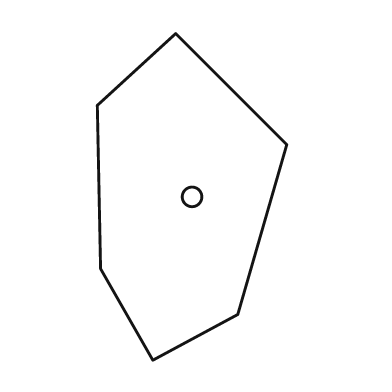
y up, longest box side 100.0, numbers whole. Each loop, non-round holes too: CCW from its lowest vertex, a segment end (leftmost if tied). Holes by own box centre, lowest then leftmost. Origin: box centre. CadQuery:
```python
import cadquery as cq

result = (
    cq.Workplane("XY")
    .moveTo(-12.0, -50.0)
    .lineTo(14.0, -36.0)
    .lineTo(29.0, 16.0)
    .lineTo(-5.0, 50.0)
    .lineTo(-29.0, 28.0)
    .lineTo(-28.0, -22.0)
    .close()
    .moveTo(0.0, 0.0)
    .circle(3.0)
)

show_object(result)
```